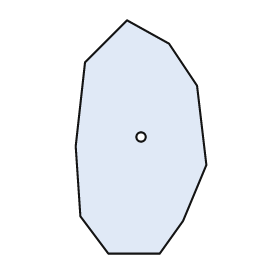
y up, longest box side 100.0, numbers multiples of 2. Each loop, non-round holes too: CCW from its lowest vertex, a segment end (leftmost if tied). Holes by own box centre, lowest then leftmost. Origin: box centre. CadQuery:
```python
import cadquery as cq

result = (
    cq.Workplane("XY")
    .moveTo(-14.0, -50.0)
    .lineTo(8.0, -50.0)
    .lineTo(18.0, -36.0)
    .lineTo(28.0, -12.0)
    .lineTo(24.0, 22.0)
    .lineTo(12.0, 40.0)
    .lineTo(-6.0, 50.0)
    .lineTo(-24.0, 32.0)
    .lineTo(-28.0, -4.0)
    .lineTo(-26.0, -34.0)
    .close()
    .moveTo(0.0, 0.0)
    .circle(2.0)
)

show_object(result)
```